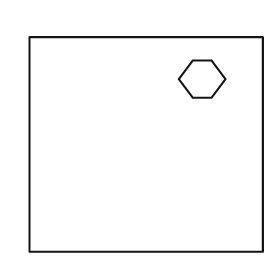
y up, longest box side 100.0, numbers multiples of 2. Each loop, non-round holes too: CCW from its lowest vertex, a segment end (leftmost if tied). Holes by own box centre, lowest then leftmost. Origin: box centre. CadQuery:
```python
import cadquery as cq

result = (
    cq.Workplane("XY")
    .moveTo(-50.0, -46.0)
    .lineTo(50.0, -46.0)
    .lineTo(50.0, 46.0)
    .lineTo(-50.0, 46.0)
    .close()
    .moveTo(20.0, 20.0)
    .lineTo(28.0, 20.0)
    .lineTo(34.0, 28.0)
    .lineTo(28.0, 36.0)
    .lineTo(20.0, 36.0)
    .lineTo(14.0, 28.0)
    .close()
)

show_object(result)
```